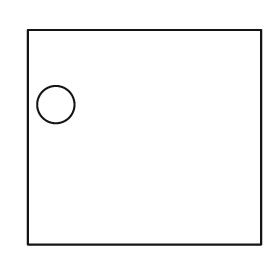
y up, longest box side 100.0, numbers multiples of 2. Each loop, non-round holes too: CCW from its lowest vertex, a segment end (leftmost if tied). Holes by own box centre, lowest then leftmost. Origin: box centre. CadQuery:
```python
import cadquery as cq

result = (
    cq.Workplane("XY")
    .moveTo(-50.0, -46.0)
    .lineTo(50.0, -46.0)
    .lineTo(50.0, 46.0)
    .lineTo(-50.0, 46.0)
    .close()
    .moveTo(-38.0, 14.0)
    .circle(8.0)
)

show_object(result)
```